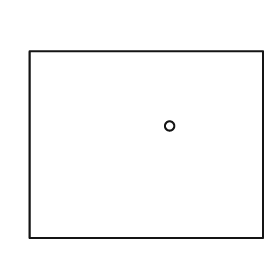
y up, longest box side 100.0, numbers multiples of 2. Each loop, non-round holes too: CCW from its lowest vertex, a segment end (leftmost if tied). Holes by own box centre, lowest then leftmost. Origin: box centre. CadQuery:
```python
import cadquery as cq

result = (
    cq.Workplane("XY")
    .moveTo(-50.0, -40.0)
    .lineTo(50.0, -40.0)
    .lineTo(50.0, 40.0)
    .lineTo(-50.0, 40.0)
    .close()
    .moveTo(10.0, 8.0)
    .circle(2.0)
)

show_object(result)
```